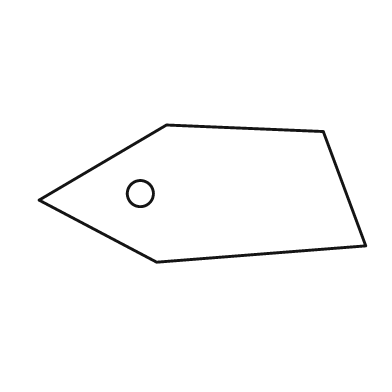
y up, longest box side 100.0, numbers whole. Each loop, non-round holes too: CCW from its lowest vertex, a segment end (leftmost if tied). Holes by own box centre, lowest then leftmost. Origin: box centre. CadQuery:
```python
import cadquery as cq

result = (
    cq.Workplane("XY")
    .moveTo(-14.0, -21.0)
    .lineTo(50.0, -16.0)
    .lineTo(37.0, 19.0)
    .lineTo(-11.0, 21.0)
    .lineTo(-50.0, -2.0)
    .close()
    .moveTo(-19.0, 0.0)
    .circle(4.0)
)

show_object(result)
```